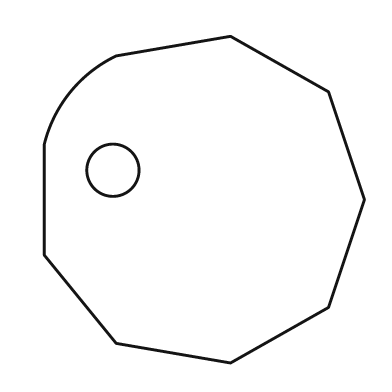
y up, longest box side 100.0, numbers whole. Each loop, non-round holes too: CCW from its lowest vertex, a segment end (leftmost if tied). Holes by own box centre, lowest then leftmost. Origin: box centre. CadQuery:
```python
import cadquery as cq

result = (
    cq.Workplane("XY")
    .moveTo(8.0, -50.0)
    .lineTo(38.0, -33.0)
    .lineTo(49.0, 0.0)
    .lineTo(38.0, 33.0)
    .lineTo(8.0, 50.0)
    .lineTo(-27.0, 44.0)
    .threePointArc((-41.0, 33.0), (-49.0, 17.0))
    .lineTo(-49.0, -17.0)
    .lineTo(-27.0, -44.0)
    .close()
    .moveTo(-28.0, 9.0)
    .circle(8.0)
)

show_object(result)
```